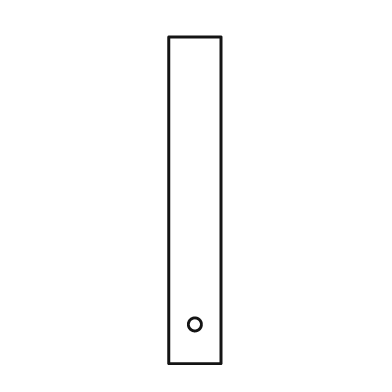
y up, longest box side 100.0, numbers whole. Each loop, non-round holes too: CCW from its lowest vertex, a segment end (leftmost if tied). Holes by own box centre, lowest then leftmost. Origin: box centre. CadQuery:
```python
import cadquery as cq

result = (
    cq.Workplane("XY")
    .moveTo(-8.0, -50.0)
    .lineTo(8.0, -50.0)
    .lineTo(8.0, 50.0)
    .lineTo(-8.0, 50.0)
    .close()
    .moveTo(0.0, -38.0)
    .circle(2.0)
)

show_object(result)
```